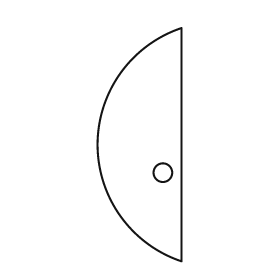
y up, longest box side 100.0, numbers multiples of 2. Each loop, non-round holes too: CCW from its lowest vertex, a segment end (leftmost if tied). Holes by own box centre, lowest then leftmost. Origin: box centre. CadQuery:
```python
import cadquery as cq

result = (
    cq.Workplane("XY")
    .moveTo(18.0, -50.0)
    .lineTo(18.0, 50.0)
    .threePointArc((-18.0, 0.0), (18.0, -50.0))
    .close()
    .moveTo(10.0, -12.0)
    .circle(4.0)
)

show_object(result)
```